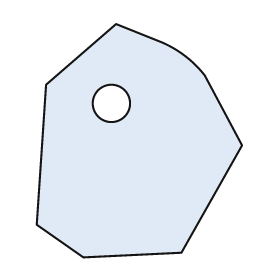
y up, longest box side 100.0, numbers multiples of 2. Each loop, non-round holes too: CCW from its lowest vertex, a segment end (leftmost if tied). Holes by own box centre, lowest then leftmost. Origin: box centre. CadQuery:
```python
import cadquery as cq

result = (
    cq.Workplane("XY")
    .moveTo(-24.0, -50.0)
    .lineTo(18.0, -48.0)
    .lineTo(44.0, -2.0)
    .lineTo(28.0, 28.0)
    .threePointArc((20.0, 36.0), (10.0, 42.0))
    .lineTo(-10.0, 50.0)
    .lineTo(-40.0, 24.0)
    .lineTo(-44.0, -36.0)
    .close()
    .moveTo(-12.0, 16.0)
    .circle(8.0)
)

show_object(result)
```